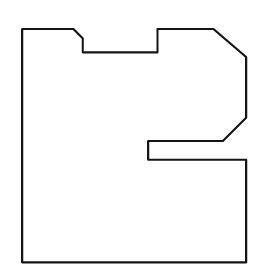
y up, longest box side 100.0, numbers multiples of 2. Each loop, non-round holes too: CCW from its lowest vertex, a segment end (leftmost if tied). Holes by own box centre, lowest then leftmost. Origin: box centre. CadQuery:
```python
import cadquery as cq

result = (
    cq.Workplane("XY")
    .moveTo(-48.0, -50.0)
    .lineTo(48.0, -50.0)
    .lineTo(48.0, -6.0)
    .lineTo(6.0, -6.0)
    .lineTo(6.0, 2.0)
    .lineTo(38.0, 2.0)
    .lineTo(48.0, 12.0)
    .lineTo(48.0, 38.0)
    .lineTo(34.0, 50.0)
    .lineTo(10.0, 50.0)
    .lineTo(10.0, 40.0)
    .lineTo(-22.0, 40.0)
    .lineTo(-22.0, 46.0)
    .lineTo(-26.0, 50.0)
    .lineTo(-48.0, 50.0)
    .close()
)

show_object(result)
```